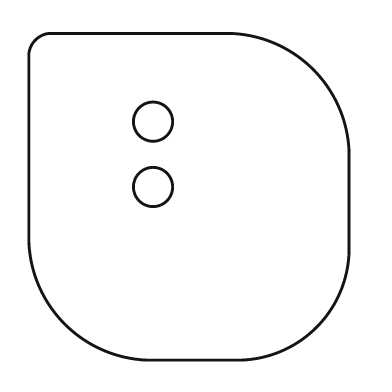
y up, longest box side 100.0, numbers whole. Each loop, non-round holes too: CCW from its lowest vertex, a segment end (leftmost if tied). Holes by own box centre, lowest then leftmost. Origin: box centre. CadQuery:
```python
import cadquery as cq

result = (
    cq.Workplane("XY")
    .moveTo(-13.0, -50.0)
    .lineTo(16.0, -50.0)
    .threePointArc((39.0, -40.0), (49.0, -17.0))
    .lineTo(49.0, 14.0)
    .threePointArc((38.0, 39.0), (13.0, 50.0))
    .lineTo(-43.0, 50.0)
    .threePointArc((-47.0, 48.0), (-49.0, 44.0))
    .lineTo(-49.0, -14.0)
    .threePointArc((-38.0, -39.0), (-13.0, -50.0))
    .close()
    .moveTo(-11.0, 3.0)
    .circle(6.0)
    .moveTo(-11.0, 23.0)
    .circle(6.0)
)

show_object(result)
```